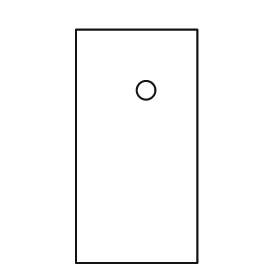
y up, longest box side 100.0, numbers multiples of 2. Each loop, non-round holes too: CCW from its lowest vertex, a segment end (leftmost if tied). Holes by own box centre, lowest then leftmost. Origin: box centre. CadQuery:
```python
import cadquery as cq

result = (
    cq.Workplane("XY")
    .moveTo(-26.0, -50.0)
    .lineTo(26.0, -50.0)
    .lineTo(26.0, 50.0)
    .lineTo(-26.0, 50.0)
    .close()
    .moveTo(4.0, 24.0)
    .circle(4.0)
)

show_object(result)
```